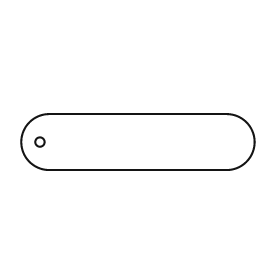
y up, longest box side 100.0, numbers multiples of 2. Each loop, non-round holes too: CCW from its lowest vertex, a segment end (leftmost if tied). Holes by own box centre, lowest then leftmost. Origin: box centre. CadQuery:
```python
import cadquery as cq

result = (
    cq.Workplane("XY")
    .moveTo(-38.0, -12.0)
    .lineTo(38.0, -12.0)
    .threePointArc((50.0, 0.0), (38.0, 12.0))
    .lineTo(-38.0, 12.0)
    .threePointArc((-50.0, 0.0), (-38.0, -12.0))
    .close()
    .moveTo(-42.0, 0.0)
    .circle(2.0)
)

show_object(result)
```